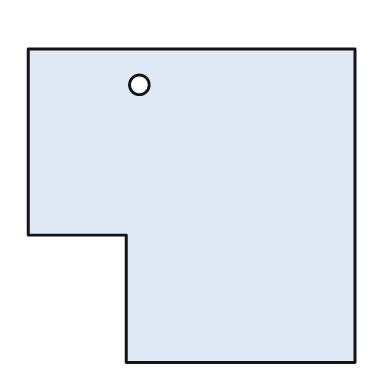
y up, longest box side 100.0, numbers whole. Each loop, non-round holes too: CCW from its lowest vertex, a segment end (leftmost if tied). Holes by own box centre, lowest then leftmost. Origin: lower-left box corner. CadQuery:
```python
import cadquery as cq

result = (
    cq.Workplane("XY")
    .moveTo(30.0, 0.0)
    .lineTo(100.0, 0.0)
    .lineTo(100.0, 96.0)
    .lineTo(0.0, 96.0)
    .lineTo(0.0, 39.0)
    .lineTo(30.0, 39.0)
    .close()
    .moveTo(34.0, 85.0)
    .circle(3.0)
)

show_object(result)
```